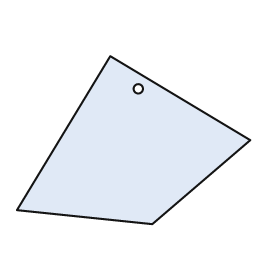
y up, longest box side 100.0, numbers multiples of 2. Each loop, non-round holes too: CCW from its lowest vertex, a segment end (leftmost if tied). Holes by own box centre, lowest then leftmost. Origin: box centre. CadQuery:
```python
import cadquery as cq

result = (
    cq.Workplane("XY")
    .moveTo(8.0, -36.0)
    .lineTo(50.0, 0.0)
    .lineTo(-10.0, 36.0)
    .lineTo(-50.0, -30.0)
    .close()
    .moveTo(2.0, 22.0)
    .circle(2.0)
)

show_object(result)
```